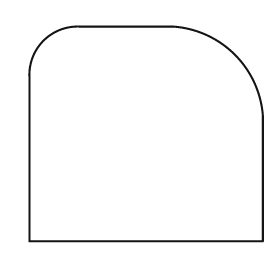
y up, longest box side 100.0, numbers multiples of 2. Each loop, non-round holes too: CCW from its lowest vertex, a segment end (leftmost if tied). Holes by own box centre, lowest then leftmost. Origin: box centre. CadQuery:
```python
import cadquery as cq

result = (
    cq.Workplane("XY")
    .moveTo(-50.0, -46.0)
    .lineTo(50.0, -46.0)
    .lineTo(50.0, 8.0)
    .threePointArc((38.0, 34.0), (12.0, 46.0))
    .lineTo(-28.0, 46.0)
    .threePointArc((-44.0, 40.0), (-50.0, 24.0))
    .close()
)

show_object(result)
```